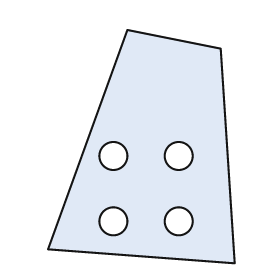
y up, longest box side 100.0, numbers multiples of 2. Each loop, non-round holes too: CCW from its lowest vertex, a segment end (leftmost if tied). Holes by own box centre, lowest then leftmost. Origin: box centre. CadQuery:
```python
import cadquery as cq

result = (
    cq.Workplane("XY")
    .moveTo(40.0, -50.0)
    .lineTo(34.0, 42.0)
    .lineTo(-6.0, 50.0)
    .lineTo(-40.0, -44.0)
    .close()
    .moveTo(-12.0, -32.0)
    .circle(6.0)
    .moveTo(16.0, -32.0)
    .circle(6.0)
    .moveTo(-12.0, -4.0)
    .circle(6.0)
    .moveTo(16.0, -4.0)
    .circle(6.0)
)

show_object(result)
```